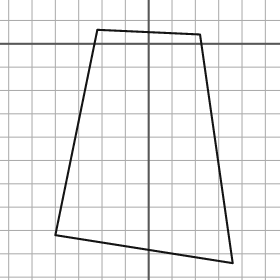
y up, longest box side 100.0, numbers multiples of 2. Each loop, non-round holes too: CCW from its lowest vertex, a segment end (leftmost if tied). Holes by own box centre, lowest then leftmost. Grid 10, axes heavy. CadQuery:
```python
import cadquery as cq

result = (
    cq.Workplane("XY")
    .moveTo(36.0, -94.0)
    .lineTo(22.0, 4.0)
    .lineTo(-22.0, 6.0)
    .lineTo(-40.0, -82.0)
    .close()
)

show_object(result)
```